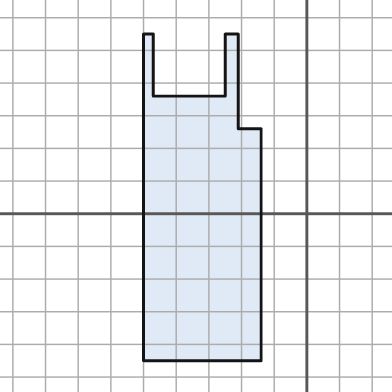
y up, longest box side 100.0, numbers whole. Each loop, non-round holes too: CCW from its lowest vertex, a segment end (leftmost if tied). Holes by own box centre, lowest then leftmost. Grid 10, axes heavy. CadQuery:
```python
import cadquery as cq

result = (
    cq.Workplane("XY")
    .moveTo(-50.0, -45.0)
    .lineTo(-14.0, -45.0)
    .lineTo(-14.0, 26.0)
    .lineTo(-21.0, 26.0)
    .lineTo(-21.0, 55.0)
    .lineTo(-25.0, 55.0)
    .lineTo(-25.0, 36.0)
    .lineTo(-47.0, 36.0)
    .lineTo(-47.0, 55.0)
    .lineTo(-50.0, 55.0)
    .close()
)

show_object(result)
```